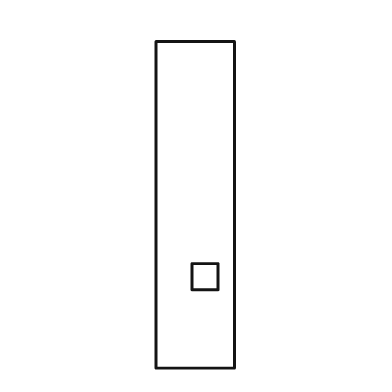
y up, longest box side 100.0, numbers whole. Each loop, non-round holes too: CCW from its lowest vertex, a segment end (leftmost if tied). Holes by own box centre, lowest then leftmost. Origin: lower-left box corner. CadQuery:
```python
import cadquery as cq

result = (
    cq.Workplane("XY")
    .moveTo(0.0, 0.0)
    .lineTo(24.0, 0.0)
    .lineTo(24.0, 100.0)
    .lineTo(0.0, 100.0)
    .close()
    .moveTo(11.0, 24.0)
    .lineTo(19.0, 24.0)
    .lineTo(19.0, 32.0)
    .lineTo(11.0, 32.0)
    .close()
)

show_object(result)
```